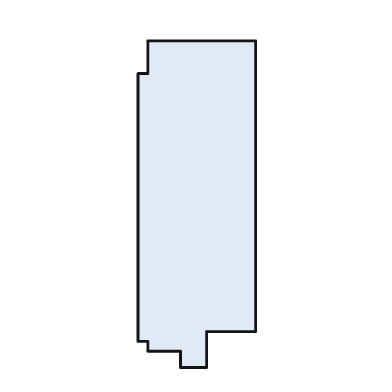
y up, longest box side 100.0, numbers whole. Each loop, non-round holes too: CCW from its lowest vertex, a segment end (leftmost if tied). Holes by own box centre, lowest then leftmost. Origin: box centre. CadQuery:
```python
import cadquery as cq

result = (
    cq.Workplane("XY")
    .moveTo(-5.0, -50.0)
    .lineTo(3.0, -50.0)
    .lineTo(3.0, -39.0)
    .lineTo(18.0, -39.0)
    .lineTo(18.0, 50.0)
    .lineTo(-15.0, 50.0)
    .lineTo(-15.0, 40.0)
    .lineTo(-18.0, 40.0)
    .lineTo(-18.0, -42.0)
    .lineTo(-15.0, -42.0)
    .lineTo(-15.0, -45.0)
    .lineTo(-5.0, -45.0)
    .close()
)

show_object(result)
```